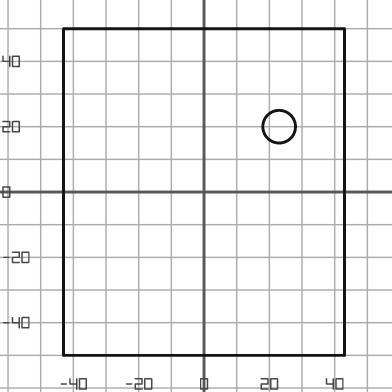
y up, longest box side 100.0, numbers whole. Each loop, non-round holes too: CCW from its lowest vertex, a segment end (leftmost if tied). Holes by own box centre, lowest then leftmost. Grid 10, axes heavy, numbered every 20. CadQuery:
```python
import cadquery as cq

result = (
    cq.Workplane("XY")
    .moveTo(-43.0, -50.0)
    .lineTo(43.0, -50.0)
    .lineTo(43.0, 50.0)
    .lineTo(-43.0, 50.0)
    .close()
    .moveTo(23.0, 20.0)
    .circle(5.0)
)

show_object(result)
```